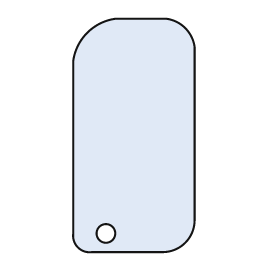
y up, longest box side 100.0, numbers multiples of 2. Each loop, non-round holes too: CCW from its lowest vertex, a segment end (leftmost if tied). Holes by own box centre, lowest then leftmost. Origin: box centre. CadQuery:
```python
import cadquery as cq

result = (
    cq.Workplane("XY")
    .moveTo(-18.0, -50.0)
    .lineTo(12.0, -50.0)
    .threePointArc((22.0, -46.0), (26.0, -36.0))
    .lineTo(26.0, 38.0)
    .threePointArc((22.0, 46.0), (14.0, 50.0))
    .lineTo(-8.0, 50.0)
    .threePointArc((-20.0, 44.0), (-26.0, 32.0))
    .lineTo(-26.0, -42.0)
    .threePointArc((-24.0, -48.0), (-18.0, -50.0))
    .close()
    .moveTo(-12.0, -42.0)
    .circle(4.0)
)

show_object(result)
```